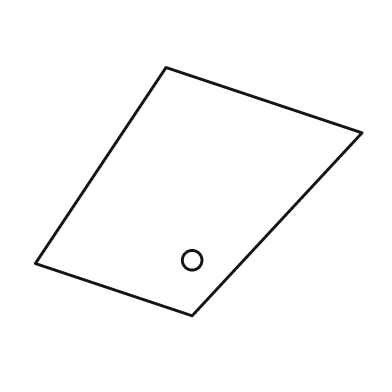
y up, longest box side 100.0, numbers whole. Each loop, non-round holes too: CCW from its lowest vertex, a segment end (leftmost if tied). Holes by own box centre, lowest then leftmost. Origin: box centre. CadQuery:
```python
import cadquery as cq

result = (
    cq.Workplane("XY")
    .moveTo(-2.0, -38.0)
    .lineTo(50.0, 18.0)
    .lineTo(-10.0, 38.0)
    .lineTo(-50.0, -22.0)
    .close()
    .moveTo(-2.0, -21.0)
    .circle(3.0)
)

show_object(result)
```